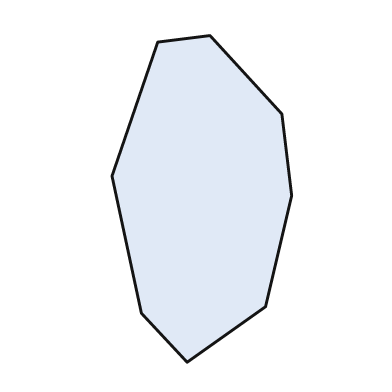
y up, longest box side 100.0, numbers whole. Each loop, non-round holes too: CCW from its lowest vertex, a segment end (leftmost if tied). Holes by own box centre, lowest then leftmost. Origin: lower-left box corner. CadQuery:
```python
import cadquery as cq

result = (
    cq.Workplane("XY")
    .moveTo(23.0, 0.0)
    .lineTo(47.0, 17.0)
    .lineTo(55.0, 51.0)
    .lineTo(52.0, 76.0)
    .lineTo(30.0, 100.0)
    .lineTo(14.0, 98.0)
    .lineTo(0.0, 57.0)
    .lineTo(9.0, 15.0)
    .close()
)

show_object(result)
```